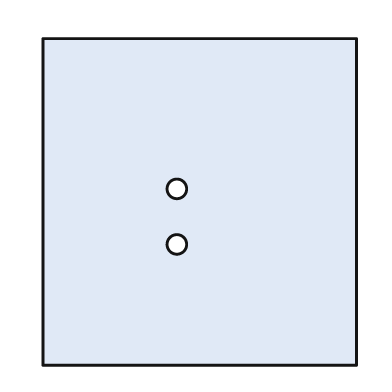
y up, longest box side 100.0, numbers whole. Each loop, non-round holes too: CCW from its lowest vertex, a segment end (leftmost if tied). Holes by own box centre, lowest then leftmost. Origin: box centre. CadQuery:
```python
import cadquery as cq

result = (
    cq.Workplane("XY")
    .moveTo(-48.0, -50.0)
    .lineTo(48.0, -50.0)
    .lineTo(48.0, 50.0)
    .lineTo(-48.0, 50.0)
    .close()
    .moveTo(-7.0, -13.0)
    .circle(3.0)
    .moveTo(-7.0, 4.0)
    .circle(3.0)
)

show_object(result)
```